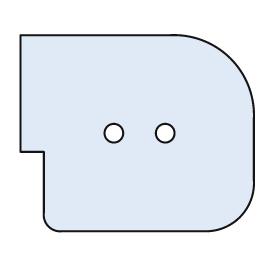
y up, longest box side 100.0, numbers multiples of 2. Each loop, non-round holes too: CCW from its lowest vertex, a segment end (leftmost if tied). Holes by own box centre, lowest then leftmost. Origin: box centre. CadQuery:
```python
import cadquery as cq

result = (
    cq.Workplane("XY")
    .moveTo(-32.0, -42.0)
    .lineTo(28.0, -42.0)
    .threePointArc((44.0, -36.0), (50.0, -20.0))
    .lineTo(50.0, 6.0)
    .threePointArc((40.0, 32.0), (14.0, 42.0))
    .lineTo(-50.0, 42.0)
    .lineTo(-50.0, -8.0)
    .lineTo(-40.0, -8.0)
    .lineTo(-40.0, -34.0)
    .threePointArc((-38.0, -40.0), (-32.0, -42.0))
    .close()
    .moveTo(-10.0, 0.0)
    .circle(4.0)
    .moveTo(12.0, 0.0)
    .circle(4.0)
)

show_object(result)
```